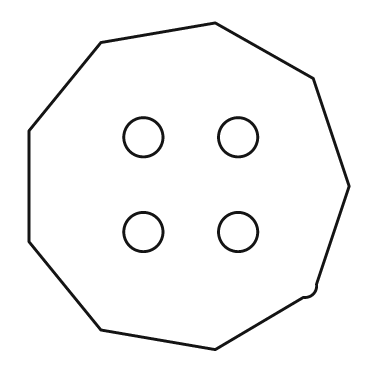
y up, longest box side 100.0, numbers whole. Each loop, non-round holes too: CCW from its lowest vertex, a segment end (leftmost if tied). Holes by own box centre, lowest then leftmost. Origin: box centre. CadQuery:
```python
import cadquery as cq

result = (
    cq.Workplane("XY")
    .moveTo(8.0, -50.0)
    .lineTo(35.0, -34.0)
    .threePointArc((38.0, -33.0), (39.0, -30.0))
    .lineTo(49.0, 0.0)
    .lineTo(38.0, 33.0)
    .lineTo(8.0, 50.0)
    .lineTo(-27.0, 44.0)
    .lineTo(-49.0, 17.0)
    .lineTo(-49.0, -17.0)
    .lineTo(-27.0, -44.0)
    .close()
    .moveTo(-14.0, -14.0)
    .circle(6.0)
    .moveTo(15.0, -14.0)
    .circle(6.0)
    .moveTo(-14.0, 15.0)
    .circle(6.0)
    .moveTo(15.0, 15.0)
    .circle(6.0)
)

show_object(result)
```